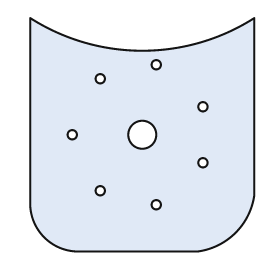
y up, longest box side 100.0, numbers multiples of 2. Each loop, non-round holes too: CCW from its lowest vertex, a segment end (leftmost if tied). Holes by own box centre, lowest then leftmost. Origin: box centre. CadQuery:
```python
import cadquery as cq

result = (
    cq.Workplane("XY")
    .moveTo(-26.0, -50.0)
    .lineTo(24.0, -50.0)
    .threePointArc((40.0, -42.0), (48.0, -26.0))
    .lineTo(48.0, 50.0)
    .threePointArc((0.0, 36.0), (-48.0, 50.0))
    .lineTo(-48.0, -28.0)
    .threePointArc((-42.0, -44.0), (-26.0, -50.0))
    .close()
    .moveTo(6.0, -30.0)
    .circle(2.0)
    .moveTo(-18.0, -24.0)
    .circle(2.0)
    .moveTo(26.0, -12.0)
    .circle(2.0)
    .moveTo(-30.0, 0.0)
    .circle(2.0)
    .moveTo(0.0, 0.0)
    .circle(6.0)
    .moveTo(26.0, 12.0)
    .circle(2.0)
    .moveTo(-18.0, 24.0)
    .circle(2.0)
    .moveTo(6.0, 30.0)
    .circle(2.0)
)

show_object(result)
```